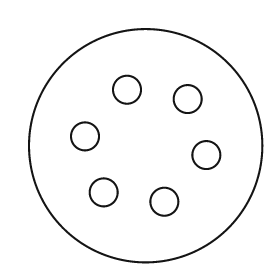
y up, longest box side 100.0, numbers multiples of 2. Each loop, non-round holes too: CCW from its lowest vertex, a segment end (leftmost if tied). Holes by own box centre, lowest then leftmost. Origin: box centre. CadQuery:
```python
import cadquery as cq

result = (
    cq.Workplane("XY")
    .moveTo(0.0, 0.0)
    .circle(50.0)
    .moveTo(8.0, -24.0)
    .circle(6.0)
    .moveTo(-18.0, -20.0)
    .circle(6.0)
    .moveTo(26.0, -4.0)
    .circle(6.0)
    .moveTo(-26.0, 4.0)
    .circle(6.0)
    .moveTo(18.0, 20.0)
    .circle(6.0)
    .moveTo(-8.0, 24.0)
    .circle(6.0)
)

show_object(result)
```